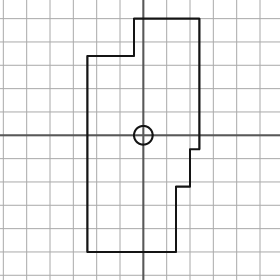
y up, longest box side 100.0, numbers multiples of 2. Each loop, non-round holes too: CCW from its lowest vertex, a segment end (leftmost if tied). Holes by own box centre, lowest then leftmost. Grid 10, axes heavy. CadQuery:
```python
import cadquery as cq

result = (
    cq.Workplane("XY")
    .moveTo(-24.0, -50.0)
    .lineTo(14.0, -50.0)
    .lineTo(14.0, -22.0)
    .lineTo(20.0, -22.0)
    .lineTo(20.0, -6.0)
    .lineTo(24.0, -6.0)
    .lineTo(24.0, 50.0)
    .lineTo(-4.0, 50.0)
    .lineTo(-4.0, 34.0)
    .lineTo(-24.0, 34.0)
    .close()
    .moveTo(0.0, 0.0)
    .circle(4.0)
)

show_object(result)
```